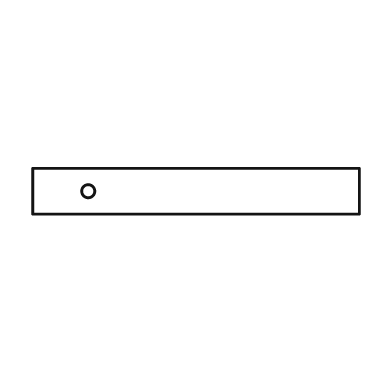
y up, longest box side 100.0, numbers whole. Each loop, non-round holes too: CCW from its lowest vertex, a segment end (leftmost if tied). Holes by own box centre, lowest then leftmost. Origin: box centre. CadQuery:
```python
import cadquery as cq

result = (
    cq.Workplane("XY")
    .moveTo(-50.0, -7.0)
    .lineTo(50.0, -7.0)
    .lineTo(50.0, 7.0)
    .lineTo(-50.0, 7.0)
    .close()
    .moveTo(-33.0, 0.0)
    .circle(2.0)
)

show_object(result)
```